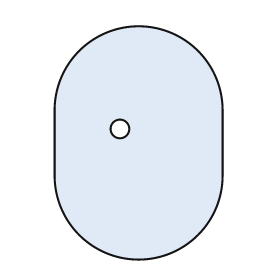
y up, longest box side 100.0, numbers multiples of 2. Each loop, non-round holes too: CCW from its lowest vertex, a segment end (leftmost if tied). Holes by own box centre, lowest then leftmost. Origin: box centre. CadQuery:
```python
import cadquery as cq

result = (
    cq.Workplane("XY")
    .moveTo(-36.0, -14.0)
    .threePointArc((0.0, -50.0), (36.0, -14.0))
    .lineTo(36.0, 14.0)
    .threePointArc((0.0, 50.0), (-36.0, 14.0))
    .close()
    .moveTo(-8.0, 6.0)
    .circle(4.0)
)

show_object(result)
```